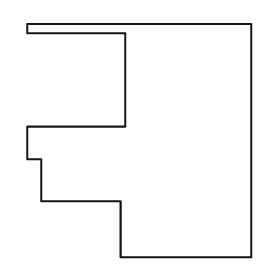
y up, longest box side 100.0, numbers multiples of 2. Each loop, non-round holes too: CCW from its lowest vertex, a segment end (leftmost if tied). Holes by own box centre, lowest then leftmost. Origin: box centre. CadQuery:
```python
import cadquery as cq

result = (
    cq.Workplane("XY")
    .moveTo(-8.0, -50.0)
    .lineTo(48.0, -50.0)
    .lineTo(48.0, 50.0)
    .lineTo(-48.0, 50.0)
    .lineTo(-48.0, 46.0)
    .lineTo(-6.0, 46.0)
    .lineTo(-6.0, 6.0)
    .lineTo(-48.0, 6.0)
    .lineTo(-48.0, -8.0)
    .lineTo(-42.0, -8.0)
    .lineTo(-42.0, -26.0)
    .lineTo(-8.0, -26.0)
    .close()
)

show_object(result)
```